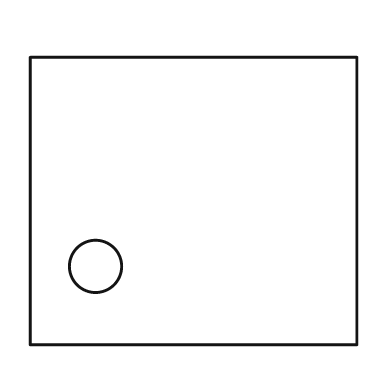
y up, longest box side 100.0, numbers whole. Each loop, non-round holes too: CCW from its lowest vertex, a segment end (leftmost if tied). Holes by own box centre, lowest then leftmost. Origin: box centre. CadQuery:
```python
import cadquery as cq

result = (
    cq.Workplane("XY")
    .moveTo(-50.0, -44.0)
    .lineTo(50.0, -44.0)
    .lineTo(50.0, 44.0)
    .lineTo(-50.0, 44.0)
    .close()
    .moveTo(-30.0, -20.0)
    .circle(8.0)
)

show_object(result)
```